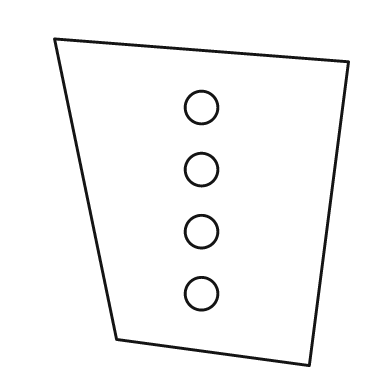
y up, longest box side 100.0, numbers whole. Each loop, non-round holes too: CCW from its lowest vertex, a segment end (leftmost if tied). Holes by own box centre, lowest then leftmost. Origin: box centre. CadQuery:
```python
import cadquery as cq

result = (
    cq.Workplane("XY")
    .moveTo(33.0, -50.0)
    .lineTo(45.0, 43.0)
    .lineTo(-45.0, 50.0)
    .lineTo(-26.0, -42.0)
    .close()
    .moveTo(0.0, -28.0)
    .circle(5.0)
    .moveTo(0.0, -9.0)
    .circle(5.0)
    .moveTo(0.0, 10.0)
    .circle(5.0)
    .moveTo(0.0, 29.0)
    .circle(5.0)
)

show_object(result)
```